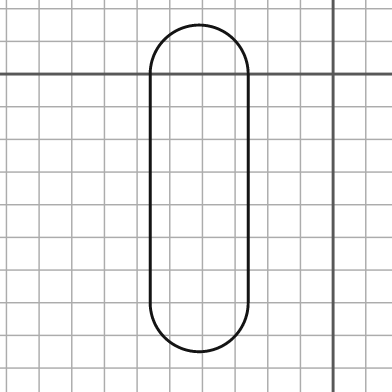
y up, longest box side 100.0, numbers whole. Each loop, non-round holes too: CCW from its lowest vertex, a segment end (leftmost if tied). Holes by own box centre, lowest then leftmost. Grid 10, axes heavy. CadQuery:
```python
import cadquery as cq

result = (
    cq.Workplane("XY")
    .moveTo(-56.0, -70.0)
    .threePointArc((-41.0, -85.0), (-26.0, -70.0))
    .lineTo(-26.0, 0.0)
    .threePointArc((-41.0, 15.0), (-56.0, 0.0))
    .close()
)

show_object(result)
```